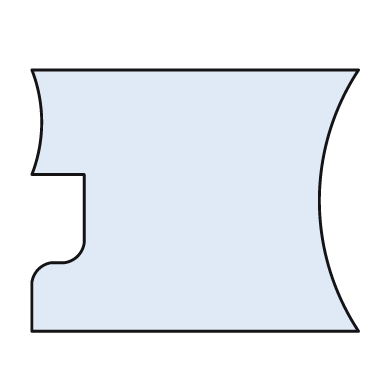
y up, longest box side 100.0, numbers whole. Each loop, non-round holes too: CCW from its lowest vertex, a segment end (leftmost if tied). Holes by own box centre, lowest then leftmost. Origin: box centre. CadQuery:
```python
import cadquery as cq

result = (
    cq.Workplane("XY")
    .moveTo(-50.0, -40.0)
    .lineTo(50.0, -40.0)
    .threePointArc((38.0, 0.0), (50.0, 40.0))
    .lineTo(-50.0, 40.0)
    .threePointArc((-47.0, 24.0), (-50.0, 8.0))
    .lineTo(-34.0, 8.0)
    .lineTo(-34.0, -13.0)
    .threePointArc((-36.0, -17.0), (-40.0, -19.0))
    .lineTo(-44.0, -19.0)
    .threePointArc((-48.0, -21.0), (-50.0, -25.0))
    .close()
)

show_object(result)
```